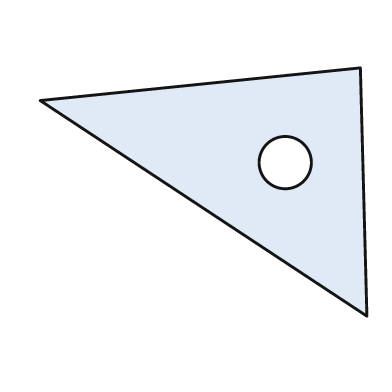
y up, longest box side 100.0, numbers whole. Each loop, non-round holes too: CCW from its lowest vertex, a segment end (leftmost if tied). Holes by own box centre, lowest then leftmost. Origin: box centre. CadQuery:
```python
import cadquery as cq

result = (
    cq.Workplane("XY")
    .moveTo(50.0, -38.0)
    .lineTo(48.0, 38.0)
    .lineTo(-50.0, 28.0)
    .close()
    .moveTo(25.0, 9.0)
    .circle(8.0)
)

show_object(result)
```